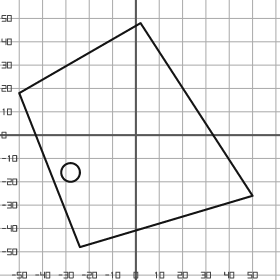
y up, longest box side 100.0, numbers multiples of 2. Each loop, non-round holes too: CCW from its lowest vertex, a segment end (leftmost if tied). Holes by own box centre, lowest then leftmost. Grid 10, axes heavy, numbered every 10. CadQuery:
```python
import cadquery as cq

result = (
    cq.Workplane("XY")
    .moveTo(-24.0, -48.0)
    .lineTo(50.0, -26.0)
    .lineTo(2.0, 48.0)
    .lineTo(-50.0, 18.0)
    .close()
    .moveTo(-28.0, -16.0)
    .circle(4.0)
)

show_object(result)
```